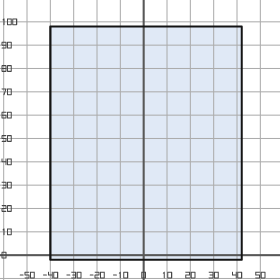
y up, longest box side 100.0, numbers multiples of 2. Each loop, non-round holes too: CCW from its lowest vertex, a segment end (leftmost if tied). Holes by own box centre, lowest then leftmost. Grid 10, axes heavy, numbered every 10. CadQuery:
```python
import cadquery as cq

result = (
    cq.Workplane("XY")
    .moveTo(-40.0, -2.0)
    .lineTo(42.0, -2.0)
    .lineTo(42.0, 98.0)
    .lineTo(-40.0, 98.0)
    .close()
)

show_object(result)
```